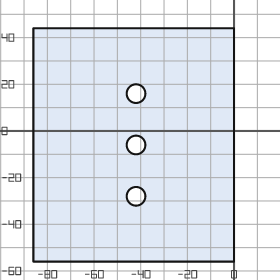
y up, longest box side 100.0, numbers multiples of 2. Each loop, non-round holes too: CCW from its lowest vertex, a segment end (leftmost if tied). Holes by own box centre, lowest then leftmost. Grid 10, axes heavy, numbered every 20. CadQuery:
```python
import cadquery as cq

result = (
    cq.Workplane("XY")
    .moveTo(-86.0, -56.0)
    .lineTo(0.0, -56.0)
    .lineTo(0.0, 44.0)
    .lineTo(-86.0, 44.0)
    .close()
    .moveTo(-42.0, -28.0)
    .circle(4.0)
    .moveTo(-42.0, -6.0)
    .circle(4.0)
    .moveTo(-42.0, 16.0)
    .circle(4.0)
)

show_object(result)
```